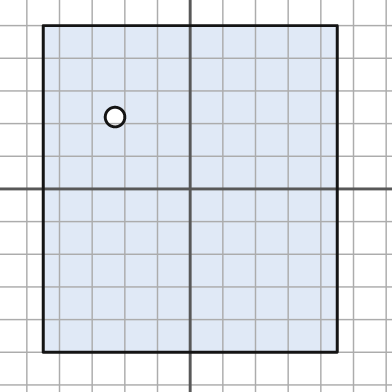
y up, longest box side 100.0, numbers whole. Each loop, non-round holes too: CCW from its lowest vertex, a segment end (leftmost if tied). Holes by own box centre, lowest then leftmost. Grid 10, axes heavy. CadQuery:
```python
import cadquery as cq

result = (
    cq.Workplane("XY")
    .moveTo(-45.0, -50.0)
    .lineTo(45.0, -50.0)
    .lineTo(45.0, 50.0)
    .lineTo(-45.0, 50.0)
    .close()
    .moveTo(-23.0, 22.0)
    .circle(3.0)
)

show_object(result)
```